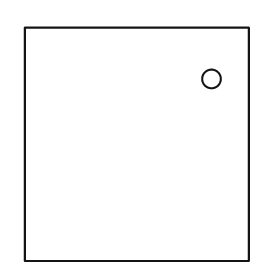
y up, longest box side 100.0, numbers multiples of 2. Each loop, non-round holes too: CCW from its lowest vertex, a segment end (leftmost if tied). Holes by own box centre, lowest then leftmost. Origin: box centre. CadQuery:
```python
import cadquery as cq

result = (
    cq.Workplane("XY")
    .moveTo(-48.0, -50.0)
    .lineTo(48.0, -50.0)
    .lineTo(48.0, 50.0)
    .lineTo(-48.0, 50.0)
    .close()
    .moveTo(32.0, 28.0)
    .circle(4.0)
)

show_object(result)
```